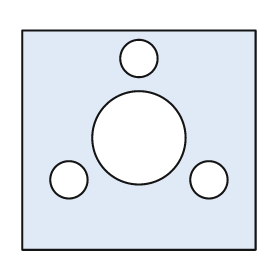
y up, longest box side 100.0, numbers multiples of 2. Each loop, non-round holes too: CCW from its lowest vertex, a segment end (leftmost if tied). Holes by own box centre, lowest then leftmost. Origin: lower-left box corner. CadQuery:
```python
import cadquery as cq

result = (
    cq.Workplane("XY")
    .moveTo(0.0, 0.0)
    .lineTo(100.0, 0.0)
    .lineTo(100.0, 94.0)
    .lineTo(0.0, 94.0)
    .close()
    .moveTo(20.0, 30.0)
    .circle(8.0)
    .moveTo(80.0, 30.0)
    .circle(8.0)
    .moveTo(50.0, 48.0)
    .circle(20.0)
    .moveTo(50.0, 82.0)
    .circle(8.0)
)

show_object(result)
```